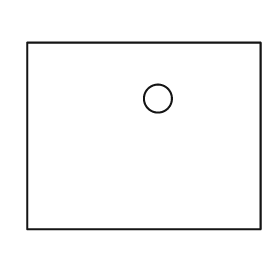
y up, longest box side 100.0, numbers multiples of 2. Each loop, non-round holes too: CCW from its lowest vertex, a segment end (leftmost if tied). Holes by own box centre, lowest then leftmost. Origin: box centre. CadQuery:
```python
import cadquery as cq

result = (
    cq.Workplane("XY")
    .moveTo(-50.0, -40.0)
    .lineTo(50.0, -40.0)
    .lineTo(50.0, 40.0)
    .lineTo(-50.0, 40.0)
    .close()
    .moveTo(6.0, 16.0)
    .circle(6.0)
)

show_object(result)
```